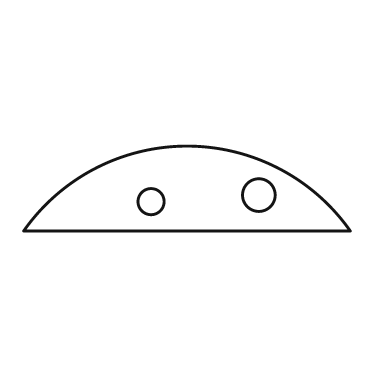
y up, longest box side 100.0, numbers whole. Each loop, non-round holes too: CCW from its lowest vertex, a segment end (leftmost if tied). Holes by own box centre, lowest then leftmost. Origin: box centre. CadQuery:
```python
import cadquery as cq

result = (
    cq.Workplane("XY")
    .moveTo(-50.0, -13.0)
    .lineTo(50.0, -13.0)
    .threePointArc((0.0, 13.0), (-50.0, -13.0))
    .close()
    .moveTo(-11.0, -4.0)
    .circle(4.0)
    .moveTo(22.0, -2.0)
    .circle(5.0)
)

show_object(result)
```